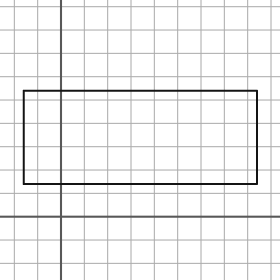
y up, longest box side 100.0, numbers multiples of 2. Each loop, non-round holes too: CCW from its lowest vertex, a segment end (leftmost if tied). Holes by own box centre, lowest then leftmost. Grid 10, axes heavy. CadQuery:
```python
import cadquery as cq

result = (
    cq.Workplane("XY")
    .moveTo(-16.0, 14.0)
    .lineTo(84.0, 14.0)
    .lineTo(84.0, 54.0)
    .lineTo(-16.0, 54.0)
    .close()
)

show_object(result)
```